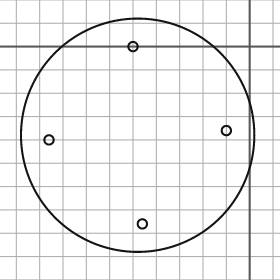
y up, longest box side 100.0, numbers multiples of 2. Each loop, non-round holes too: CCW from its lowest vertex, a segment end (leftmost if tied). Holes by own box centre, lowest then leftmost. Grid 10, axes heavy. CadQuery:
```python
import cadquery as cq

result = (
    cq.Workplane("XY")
    .moveTo(-48.0, -38.0)
    .circle(50.0)
    .moveTo(-46.0, -76.0)
    .circle(2.0)
    .moveTo(-86.0, -40.0)
    .circle(2.0)
    .moveTo(-10.0, -36.0)
    .circle(2.0)
    .moveTo(-50.0, 0.0)
    .circle(2.0)
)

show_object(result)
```